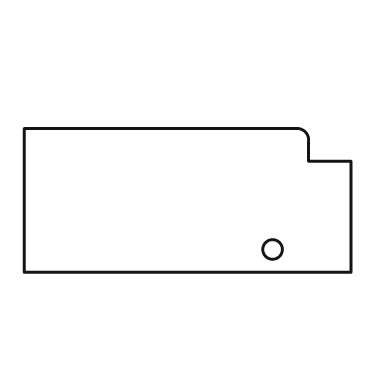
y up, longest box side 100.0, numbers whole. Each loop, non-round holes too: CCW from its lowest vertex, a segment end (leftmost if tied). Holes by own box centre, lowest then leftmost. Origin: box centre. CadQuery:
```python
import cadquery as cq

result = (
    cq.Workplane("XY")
    .moveTo(-50.0, -22.0)
    .lineTo(50.0, -22.0)
    .lineTo(50.0, 12.0)
    .lineTo(37.0, 12.0)
    .lineTo(37.0, 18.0)
    .threePointArc((36.0, 21.0), (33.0, 22.0))
    .lineTo(-50.0, 22.0)
    .close()
    .moveTo(26.0, -15.0)
    .circle(3.0)
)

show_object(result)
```